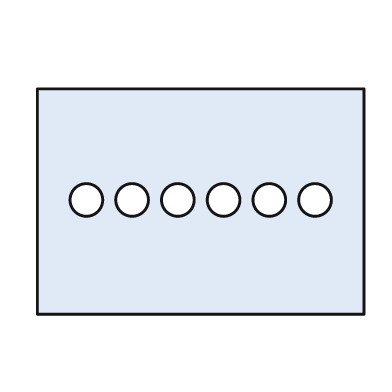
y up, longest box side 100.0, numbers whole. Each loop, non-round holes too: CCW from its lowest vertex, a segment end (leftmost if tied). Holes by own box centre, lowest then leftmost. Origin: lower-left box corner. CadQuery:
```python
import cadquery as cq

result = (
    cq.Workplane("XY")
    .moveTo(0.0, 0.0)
    .lineTo(100.0, 0.0)
    .lineTo(100.0, 69.0)
    .lineTo(0.0, 69.0)
    .close()
    .moveTo(15.0, 35.0)
    .circle(5.0)
    .moveTo(29.0, 35.0)
    .circle(5.0)
    .moveTo(43.0, 35.0)
    .circle(5.0)
    .moveTo(57.0, 35.0)
    .circle(5.0)
    .moveTo(71.0, 35.0)
    .circle(5.0)
    .moveTo(85.0, 35.0)
    .circle(5.0)
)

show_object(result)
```